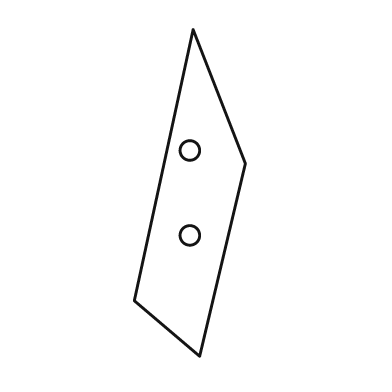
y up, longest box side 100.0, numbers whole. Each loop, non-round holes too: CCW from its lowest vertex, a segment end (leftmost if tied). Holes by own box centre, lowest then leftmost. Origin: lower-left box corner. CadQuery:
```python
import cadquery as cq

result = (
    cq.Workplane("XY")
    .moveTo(20.0, 0.0)
    .lineTo(34.0, 59.0)
    .lineTo(18.0, 100.0)
    .lineTo(0.0, 17.0)
    .close()
    .moveTo(17.0, 37.0)
    .circle(3.0)
    .moveTo(17.0, 63.0)
    .circle(3.0)
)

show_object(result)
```